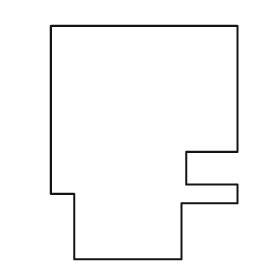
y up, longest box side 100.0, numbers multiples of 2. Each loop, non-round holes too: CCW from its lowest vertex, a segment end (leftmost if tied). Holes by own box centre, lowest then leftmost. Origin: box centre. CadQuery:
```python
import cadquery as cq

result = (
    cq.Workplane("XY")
    .moveTo(-30.0, -50.0)
    .lineTo(16.0, -50.0)
    .lineTo(16.0, -26.0)
    .lineTo(40.0, -26.0)
    .lineTo(40.0, -18.0)
    .lineTo(18.0, -18.0)
    .lineTo(18.0, -4.0)
    .lineTo(40.0, -4.0)
    .lineTo(40.0, 50.0)
    .lineTo(-40.0, 50.0)
    .lineTo(-40.0, -22.0)
    .lineTo(-30.0, -22.0)
    .close()
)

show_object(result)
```